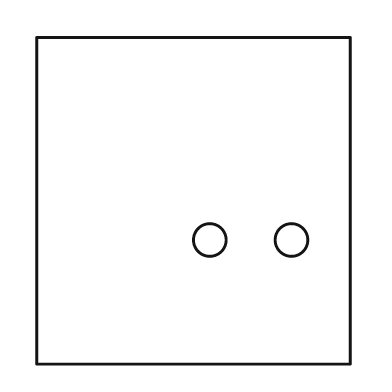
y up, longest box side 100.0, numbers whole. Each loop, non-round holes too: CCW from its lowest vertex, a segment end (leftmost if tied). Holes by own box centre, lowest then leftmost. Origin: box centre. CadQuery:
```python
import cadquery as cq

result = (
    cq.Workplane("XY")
    .moveTo(-48.0, -50.0)
    .lineTo(48.0, -50.0)
    .lineTo(48.0, 50.0)
    .lineTo(-48.0, 50.0)
    .close()
    .moveTo(5.0, -12.0)
    .circle(5.0)
    .moveTo(30.0, -12.0)
    .circle(5.0)
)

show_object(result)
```